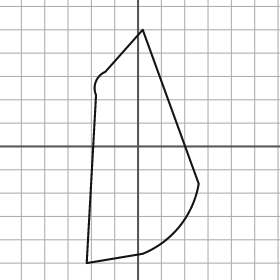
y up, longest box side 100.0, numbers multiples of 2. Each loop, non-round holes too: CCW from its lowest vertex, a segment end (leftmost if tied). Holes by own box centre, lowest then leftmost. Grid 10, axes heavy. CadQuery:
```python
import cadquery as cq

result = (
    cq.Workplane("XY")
    .moveTo(-22.0, -50.0)
    .lineTo(2.0, -46.0)
    .threePointArc((18.0, -34.0), (26.0, -16.0))
    .lineTo(2.0, 50.0)
    .lineTo(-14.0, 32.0)
    .threePointArc((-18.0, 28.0), (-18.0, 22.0))
    .close()
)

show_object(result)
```